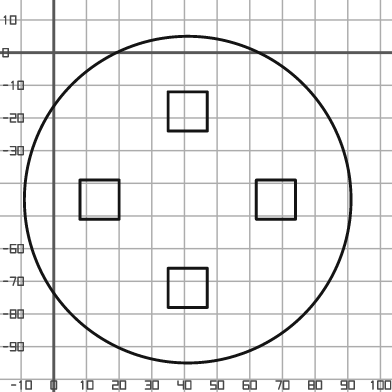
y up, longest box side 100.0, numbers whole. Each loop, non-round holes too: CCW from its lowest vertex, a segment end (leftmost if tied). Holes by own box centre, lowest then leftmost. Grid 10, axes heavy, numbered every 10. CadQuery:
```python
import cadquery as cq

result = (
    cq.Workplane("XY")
    .moveTo(41.0, -45.0)
    .circle(50.0)
    .moveTo(35.0, -78.0)
    .lineTo(47.0, -78.0)
    .lineTo(47.0, -66.0)
    .lineTo(35.0, -66.0)
    .close()
    .moveTo(8.0, -51.0)
    .lineTo(20.0, -51.0)
    .lineTo(20.0, -39.0)
    .lineTo(8.0, -39.0)
    .close()
    .moveTo(62.0, -51.0)
    .lineTo(74.0, -51.0)
    .lineTo(74.0, -39.0)
    .lineTo(62.0, -39.0)
    .close()
    .moveTo(35.0, -24.0)
    .lineTo(47.0, -24.0)
    .lineTo(47.0, -12.0)
    .lineTo(35.0, -12.0)
    .close()
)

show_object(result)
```